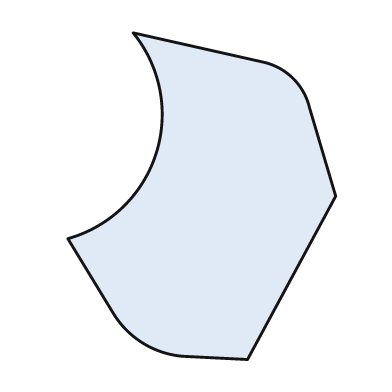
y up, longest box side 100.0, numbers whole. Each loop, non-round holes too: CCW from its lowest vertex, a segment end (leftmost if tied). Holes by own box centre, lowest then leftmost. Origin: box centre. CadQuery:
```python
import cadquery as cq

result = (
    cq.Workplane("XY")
    .moveTo(14.0, -50.0)
    .lineTo(41.0, 0.0)
    .lineTo(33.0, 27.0)
    .threePointArc((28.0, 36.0), (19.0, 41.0))
    .lineTo(-21.0, 50.0)
    .threePointArc((-14.0, 13.0), (-41.0, -13.0))
    .lineTo(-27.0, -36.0)
    .threePointArc((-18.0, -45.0), (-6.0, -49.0))
    .close()
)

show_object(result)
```